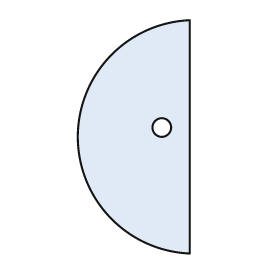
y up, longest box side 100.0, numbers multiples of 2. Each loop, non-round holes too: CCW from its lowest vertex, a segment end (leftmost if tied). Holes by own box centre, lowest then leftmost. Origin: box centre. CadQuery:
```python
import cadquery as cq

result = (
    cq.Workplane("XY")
    .moveTo(24.0, -50.0)
    .lineTo(24.0, 50.0)
    .threePointArc((-24.0, 0.0), (24.0, -50.0))
    .close()
    .moveTo(12.0, 4.0)
    .circle(4.0)
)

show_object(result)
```